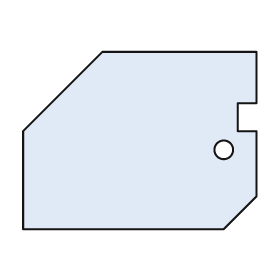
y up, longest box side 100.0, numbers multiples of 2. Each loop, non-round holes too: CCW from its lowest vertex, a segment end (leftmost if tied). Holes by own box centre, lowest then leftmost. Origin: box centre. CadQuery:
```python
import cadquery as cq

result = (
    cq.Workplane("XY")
    .moveTo(-50.0, -38.0)
    .lineTo(36.0, -38.0)
    .lineTo(50.0, -24.0)
    .lineTo(50.0, 4.0)
    .lineTo(42.0, 4.0)
    .lineTo(42.0, 16.0)
    .lineTo(50.0, 16.0)
    .lineTo(50.0, 38.0)
    .lineTo(-16.0, 38.0)
    .lineTo(-50.0, 4.0)
    .close()
    .moveTo(36.0, -4.0)
    .circle(4.0)
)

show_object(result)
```